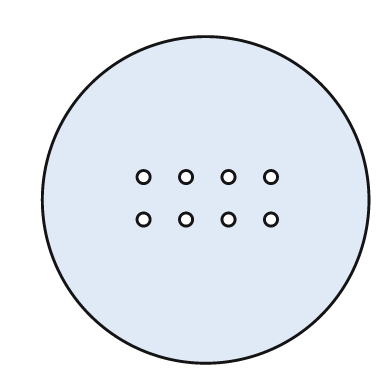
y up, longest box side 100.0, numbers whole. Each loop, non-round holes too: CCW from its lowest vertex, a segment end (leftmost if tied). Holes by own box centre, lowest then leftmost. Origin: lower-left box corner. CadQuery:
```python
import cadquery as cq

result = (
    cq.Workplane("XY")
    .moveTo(50.0, 50.0)
    .circle(50.0)
    .moveTo(31.0, 44.0)
    .circle(2.0)
    .moveTo(44.0, 44.0)
    .circle(2.0)
    .moveTo(57.0, 44.0)
    .circle(2.0)
    .moveTo(70.0, 44.0)
    .circle(2.0)
    .moveTo(31.0, 57.0)
    .circle(2.0)
    .moveTo(44.0, 57.0)
    .circle(2.0)
    .moveTo(57.0, 57.0)
    .circle(2.0)
    .moveTo(70.0, 57.0)
    .circle(2.0)
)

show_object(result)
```